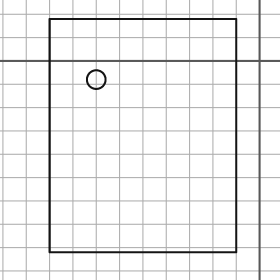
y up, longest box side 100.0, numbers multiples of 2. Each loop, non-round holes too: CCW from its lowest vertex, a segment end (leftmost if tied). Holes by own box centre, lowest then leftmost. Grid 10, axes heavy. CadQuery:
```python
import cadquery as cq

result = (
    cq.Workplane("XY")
    .moveTo(-90.0, -82.0)
    .lineTo(-10.0, -82.0)
    .lineTo(-10.0, 18.0)
    .lineTo(-90.0, 18.0)
    .close()
    .moveTo(-70.0, -8.0)
    .circle(4.0)
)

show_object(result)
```